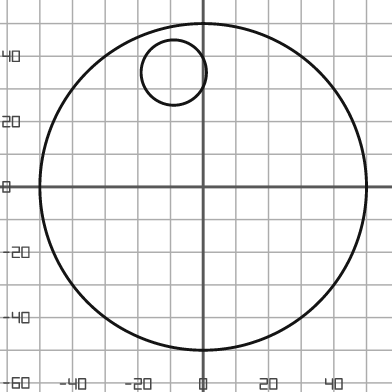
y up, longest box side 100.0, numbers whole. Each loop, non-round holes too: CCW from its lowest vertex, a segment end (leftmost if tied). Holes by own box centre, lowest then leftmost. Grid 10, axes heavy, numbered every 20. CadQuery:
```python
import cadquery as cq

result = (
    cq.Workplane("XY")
    .moveTo(0.0, 0.0)
    .circle(50.0)
    .moveTo(-9.0, 35.0)
    .circle(10.0)
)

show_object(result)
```